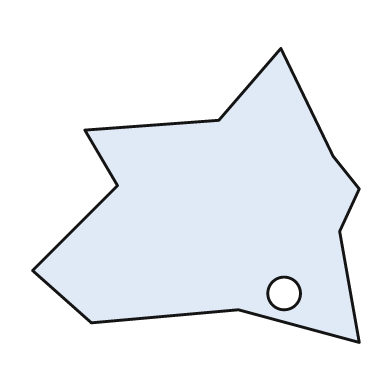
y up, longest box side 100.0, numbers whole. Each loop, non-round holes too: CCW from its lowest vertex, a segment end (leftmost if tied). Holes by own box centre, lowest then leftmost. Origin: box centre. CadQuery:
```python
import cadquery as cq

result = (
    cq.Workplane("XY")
    .moveTo(50.0, -45.0)
    .lineTo(44.0, -11.0)
    .lineTo(50.0, 2.0)
    .lineTo(42.0, 12.0)
    .lineTo(26.0, 45.0)
    .lineTo(7.0, 23.0)
    .lineTo(-34.0, 20.0)
    .lineTo(-24.0, 3.0)
    .lineTo(-50.0, -23.0)
    .lineTo(-32.0, -39.0)
    .lineTo(13.0, -35.0)
    .close()
    .moveTo(27.0, -30.0)
    .circle(5.0)
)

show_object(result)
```